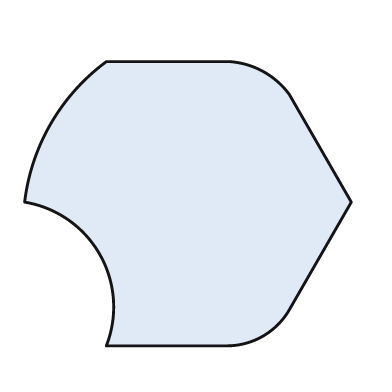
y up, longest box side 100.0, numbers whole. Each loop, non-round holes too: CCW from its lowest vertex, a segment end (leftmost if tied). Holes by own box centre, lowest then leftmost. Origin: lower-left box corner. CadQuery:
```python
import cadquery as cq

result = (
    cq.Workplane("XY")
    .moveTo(25.0, 0.0)
    .lineTo(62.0, 0.0)
    .threePointArc((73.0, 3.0), (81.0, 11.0))
    .lineTo(100.0, 44.0)
    .lineTo(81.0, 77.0)
    .threePointArc((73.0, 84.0), (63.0, 87.0))
    .lineTo(25.0, 87.0)
    .threePointArc((8.0, 68.0), (0.0, 44.0))
    .threePointArc((23.0, 28.0), (25.0, 0.0))
    .close()
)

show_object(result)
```